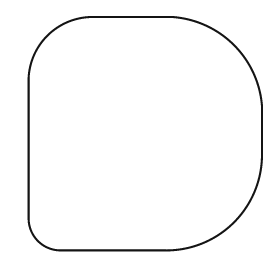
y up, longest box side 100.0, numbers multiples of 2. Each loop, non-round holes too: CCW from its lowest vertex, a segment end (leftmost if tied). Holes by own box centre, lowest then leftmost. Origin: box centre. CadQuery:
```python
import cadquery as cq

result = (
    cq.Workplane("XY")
    .moveTo(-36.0, -50.0)
    .lineTo(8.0, -50.0)
    .threePointArc((38.0, -38.0), (50.0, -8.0))
    .lineTo(50.0, 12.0)
    .threePointArc((38.0, 38.0), (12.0, 50.0))
    .lineTo(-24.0, 50.0)
    .threePointArc((-42.0, 42.0), (-50.0, 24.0))
    .lineTo(-50.0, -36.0)
    .threePointArc((-46.0, -46.0), (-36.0, -50.0))
    .close()
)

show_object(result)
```